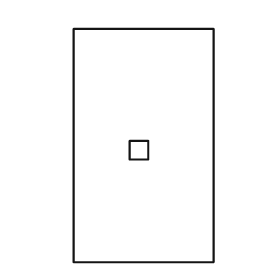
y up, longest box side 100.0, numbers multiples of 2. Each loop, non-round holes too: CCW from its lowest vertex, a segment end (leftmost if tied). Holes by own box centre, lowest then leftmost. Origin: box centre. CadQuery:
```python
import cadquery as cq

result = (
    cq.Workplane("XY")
    .moveTo(-30.0, -50.0)
    .lineTo(30.0, -50.0)
    .lineTo(30.0, 50.0)
    .lineTo(-30.0, 50.0)
    .close()
    .moveTo(-6.0, -6.0)
    .lineTo(2.0, -6.0)
    .lineTo(2.0, 2.0)
    .lineTo(-6.0, 2.0)
    .close()
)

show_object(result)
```